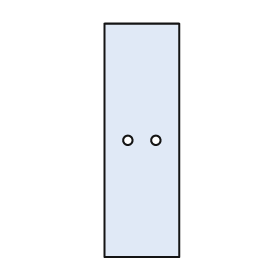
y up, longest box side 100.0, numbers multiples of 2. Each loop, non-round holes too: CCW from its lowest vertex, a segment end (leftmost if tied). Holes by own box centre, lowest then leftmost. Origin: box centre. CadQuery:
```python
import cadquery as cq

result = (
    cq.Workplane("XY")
    .moveTo(-16.0, -50.0)
    .lineTo(16.0, -50.0)
    .lineTo(16.0, 50.0)
    .lineTo(-16.0, 50.0)
    .close()
    .moveTo(-6.0, 0.0)
    .circle(2.0)
    .moveTo(6.0, 0.0)
    .circle(2.0)
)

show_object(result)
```